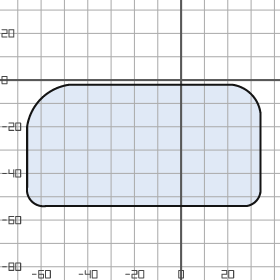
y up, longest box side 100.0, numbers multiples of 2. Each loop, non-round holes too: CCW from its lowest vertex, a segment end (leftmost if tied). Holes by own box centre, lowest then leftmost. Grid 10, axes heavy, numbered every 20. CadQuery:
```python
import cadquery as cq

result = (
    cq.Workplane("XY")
    .moveTo(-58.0, -54.0)
    .lineTo(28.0, -54.0)
    .threePointArc((32.0, -52.0), (34.0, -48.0))
    .lineTo(34.0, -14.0)
    .threePointArc((30.0, -6.0), (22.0, -2.0))
    .lineTo(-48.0, -2.0)
    .threePointArc((-60.0, -8.0), (-66.0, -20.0))
    .lineTo(-66.0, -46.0)
    .threePointArc((-64.0, -52.0), (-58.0, -54.0))
    .close()
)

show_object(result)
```